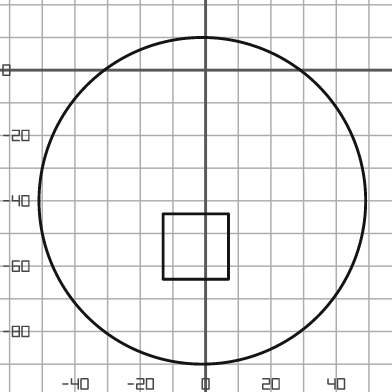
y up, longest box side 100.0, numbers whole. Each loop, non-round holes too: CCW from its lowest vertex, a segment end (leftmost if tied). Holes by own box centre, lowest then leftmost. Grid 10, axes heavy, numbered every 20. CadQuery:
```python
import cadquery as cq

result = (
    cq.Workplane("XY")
    .moveTo(-1.0, -40.0)
    .circle(50.0)
    .moveTo(-13.0, -64.0)
    .lineTo(7.0, -64.0)
    .lineTo(7.0, -44.0)
    .lineTo(-13.0, -44.0)
    .close()
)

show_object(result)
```